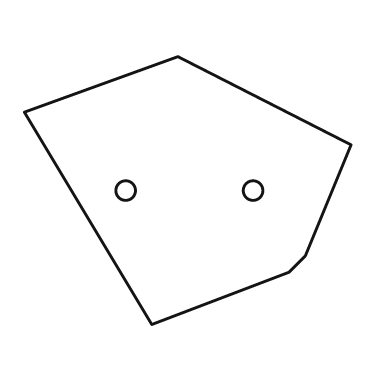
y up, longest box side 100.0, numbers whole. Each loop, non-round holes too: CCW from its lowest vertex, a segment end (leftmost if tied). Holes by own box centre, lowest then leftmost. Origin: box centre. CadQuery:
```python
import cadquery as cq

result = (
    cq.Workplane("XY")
    .moveTo(-11.0, -41.0)
    .lineTo(31.0, -25.0)
    .lineTo(36.0, -20.0)
    .lineTo(50.0, 14.0)
    .lineTo(-3.0, 41.0)
    .lineTo(-50.0, 24.0)
    .close()
    .moveTo(-19.0, 0.0)
    .circle(3.0)
    .moveTo(20.0, 0.0)
    .circle(3.0)
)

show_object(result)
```